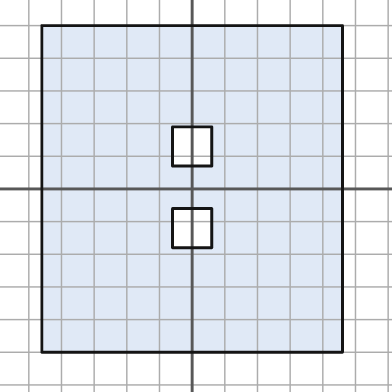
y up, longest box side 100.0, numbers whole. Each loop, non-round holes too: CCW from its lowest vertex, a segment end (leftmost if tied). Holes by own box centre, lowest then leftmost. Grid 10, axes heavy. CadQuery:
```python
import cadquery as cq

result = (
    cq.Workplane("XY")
    .moveTo(-46.0, -50.0)
    .lineTo(46.0, -50.0)
    .lineTo(46.0, 50.0)
    .lineTo(-46.0, 50.0)
    .close()
    .moveTo(-6.0, -18.0)
    .lineTo(6.0, -18.0)
    .lineTo(6.0, -6.0)
    .lineTo(-6.0, -6.0)
    .close()
    .moveTo(-6.0, 7.0)
    .lineTo(6.0, 7.0)
    .lineTo(6.0, 19.0)
    .lineTo(-6.0, 19.0)
    .close()
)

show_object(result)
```